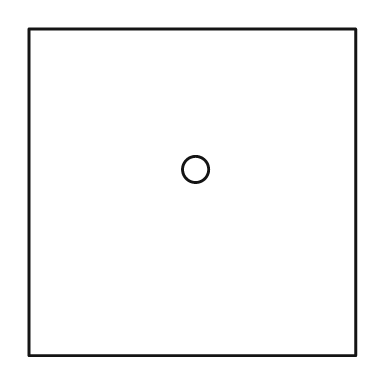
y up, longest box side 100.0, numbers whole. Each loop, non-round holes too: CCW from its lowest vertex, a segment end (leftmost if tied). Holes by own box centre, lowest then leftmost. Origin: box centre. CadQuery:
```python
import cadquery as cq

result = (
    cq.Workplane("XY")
    .moveTo(-50.0, -50.0)
    .lineTo(50.0, -50.0)
    .lineTo(50.0, 50.0)
    .lineTo(-50.0, 50.0)
    .close()
    .moveTo(1.0, 7.0)
    .circle(4.0)
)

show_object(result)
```